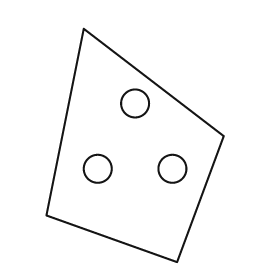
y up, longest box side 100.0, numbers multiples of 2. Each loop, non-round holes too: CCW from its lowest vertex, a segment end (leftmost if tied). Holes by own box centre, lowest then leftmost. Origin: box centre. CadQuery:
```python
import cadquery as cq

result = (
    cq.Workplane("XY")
    .moveTo(18.0, -50.0)
    .lineTo(38.0, 4.0)
    .lineTo(-22.0, 50.0)
    .lineTo(-38.0, -30.0)
    .close()
    .moveTo(-16.0, -10.0)
    .circle(6.0)
    .moveTo(16.0, -10.0)
    .circle(6.0)
    .moveTo(0.0, 18.0)
    .circle(6.0)
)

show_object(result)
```